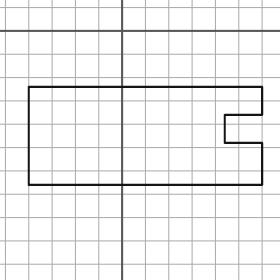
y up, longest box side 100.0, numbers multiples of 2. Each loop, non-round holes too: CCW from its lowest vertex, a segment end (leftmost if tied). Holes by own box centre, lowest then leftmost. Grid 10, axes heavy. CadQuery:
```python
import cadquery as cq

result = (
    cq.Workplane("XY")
    .moveTo(-40.0, -66.0)
    .lineTo(60.0, -66.0)
    .lineTo(60.0, -48.0)
    .lineTo(44.0, -48.0)
    .lineTo(44.0, -36.0)
    .lineTo(60.0, -36.0)
    .lineTo(60.0, -24.0)
    .lineTo(-40.0, -24.0)
    .close()
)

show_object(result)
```